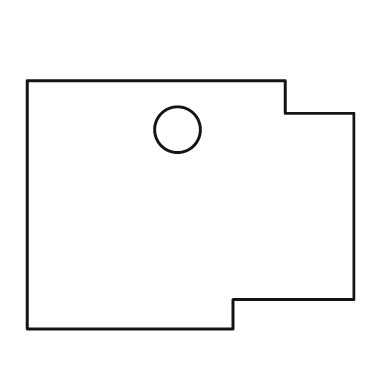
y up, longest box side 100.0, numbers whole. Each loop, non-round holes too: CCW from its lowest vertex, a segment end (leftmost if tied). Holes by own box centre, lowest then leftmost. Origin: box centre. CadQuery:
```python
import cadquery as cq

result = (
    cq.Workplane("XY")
    .moveTo(-50.0, -38.0)
    .lineTo(13.0, -38.0)
    .lineTo(13.0, -29.0)
    .lineTo(50.0, -29.0)
    .lineTo(50.0, 28.0)
    .lineTo(29.0, 28.0)
    .lineTo(29.0, 38.0)
    .lineTo(-50.0, 38.0)
    .close()
    .moveTo(-4.0, 23.0)
    .circle(7.0)
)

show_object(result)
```